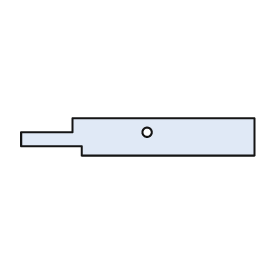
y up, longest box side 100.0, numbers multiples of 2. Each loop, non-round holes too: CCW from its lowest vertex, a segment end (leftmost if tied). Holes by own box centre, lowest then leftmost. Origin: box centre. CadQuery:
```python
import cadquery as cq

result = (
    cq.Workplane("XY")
    .moveTo(-24.0, -8.0)
    .lineTo(50.0, -8.0)
    .lineTo(50.0, 8.0)
    .lineTo(-28.0, 8.0)
    .lineTo(-28.0, 2.0)
    .lineTo(-50.0, 2.0)
    .lineTo(-50.0, -4.0)
    .lineTo(-24.0, -4.0)
    .close()
    .moveTo(4.0, 2.0)
    .circle(2.0)
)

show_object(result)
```